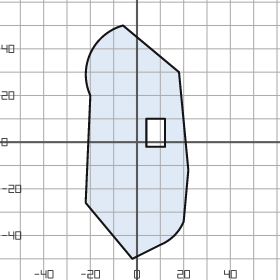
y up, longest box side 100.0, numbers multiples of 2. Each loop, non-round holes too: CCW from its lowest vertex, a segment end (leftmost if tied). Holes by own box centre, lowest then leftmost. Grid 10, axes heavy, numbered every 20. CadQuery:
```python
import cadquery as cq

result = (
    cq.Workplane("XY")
    .moveTo(-2.0, -50.0)
    .lineTo(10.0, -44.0)
    .threePointArc((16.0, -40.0), (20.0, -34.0))
    .lineTo(22.0, -12.0)
    .lineTo(18.0, 30.0)
    .lineTo(-6.0, 50.0)
    .threePointArc((-20.0, 38.0), (-20.0, 20.0))
    .lineTo(-22.0, -26.0)
    .close()
    .moveTo(4.0, -2.0)
    .lineTo(12.0, -2.0)
    .lineTo(12.0, 10.0)
    .lineTo(4.0, 10.0)
    .close()
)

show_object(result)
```